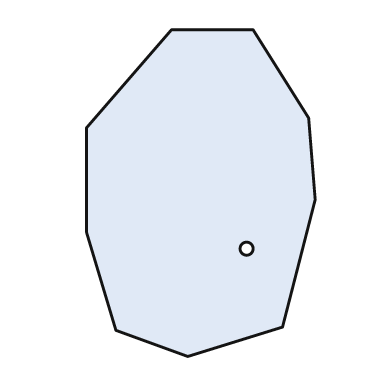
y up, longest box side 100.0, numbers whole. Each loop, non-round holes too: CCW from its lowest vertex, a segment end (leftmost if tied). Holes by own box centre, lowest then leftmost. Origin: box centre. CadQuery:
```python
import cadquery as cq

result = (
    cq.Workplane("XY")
    .moveTo(-4.0, -50.0)
    .lineTo(25.0, -41.0)
    .lineTo(35.0, -2.0)
    .lineTo(33.0, 23.0)
    .lineTo(16.0, 50.0)
    .lineTo(-9.0, 50.0)
    .lineTo(-35.0, 20.0)
    .lineTo(-35.0, -12.0)
    .lineTo(-26.0, -42.0)
    .close()
    .moveTo(14.0, -17.0)
    .circle(2.0)
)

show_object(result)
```